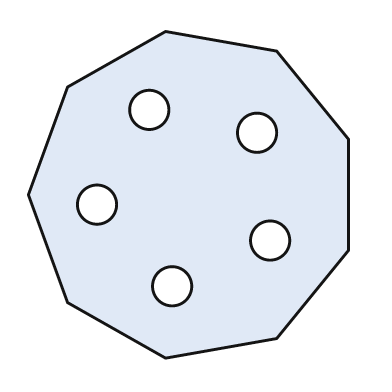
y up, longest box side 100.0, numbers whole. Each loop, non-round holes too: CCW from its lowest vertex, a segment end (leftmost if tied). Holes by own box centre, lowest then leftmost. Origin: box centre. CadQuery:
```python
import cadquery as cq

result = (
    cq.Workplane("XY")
    .moveTo(-7.0, -50.0)
    .lineTo(27.0, -44.0)
    .lineTo(49.0, -17.0)
    .lineTo(49.0, 17.0)
    .lineTo(27.0, 44.0)
    .lineTo(-7.0, 50.0)
    .lineTo(-37.0, 33.0)
    .lineTo(-49.0, 0.0)
    .lineTo(-37.0, -33.0)
    .close()
    .moveTo(-5.0, -28.0)
    .circle(6.0)
    .moveTo(25.0, -14.0)
    .circle(6.0)
    .moveTo(-28.0, -3.0)
    .circle(6.0)
    .moveTo(21.0, 19.0)
    .circle(6.0)
    .moveTo(-12.0, 26.0)
    .circle(6.0)
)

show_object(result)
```